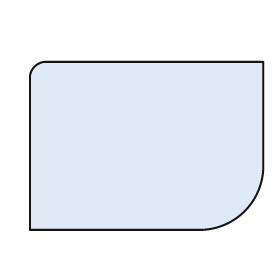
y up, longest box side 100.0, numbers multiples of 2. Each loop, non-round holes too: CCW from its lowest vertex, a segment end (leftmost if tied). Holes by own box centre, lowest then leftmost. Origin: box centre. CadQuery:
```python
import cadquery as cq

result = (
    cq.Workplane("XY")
    .moveTo(-50.0, -36.0)
    .lineTo(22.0, -36.0)
    .threePointArc((42.0, -28.0), (50.0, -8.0))
    .lineTo(50.0, 36.0)
    .lineTo(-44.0, 36.0)
    .threePointArc((-48.0, 34.0), (-50.0, 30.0))
    .close()
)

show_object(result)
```